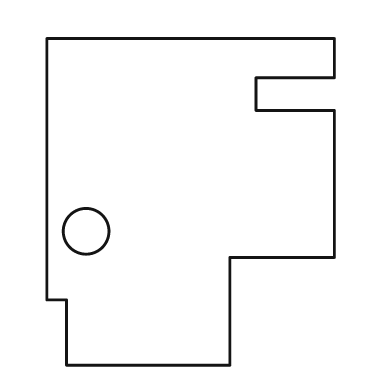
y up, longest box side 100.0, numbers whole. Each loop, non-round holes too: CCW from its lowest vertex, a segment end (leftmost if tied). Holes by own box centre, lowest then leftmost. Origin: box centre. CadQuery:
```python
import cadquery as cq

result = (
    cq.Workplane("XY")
    .moveTo(-38.0, -50.0)
    .lineTo(12.0, -50.0)
    .lineTo(12.0, -17.0)
    .lineTo(44.0, -17.0)
    .lineTo(44.0, 28.0)
    .lineTo(20.0, 28.0)
    .lineTo(20.0, 38.0)
    .lineTo(44.0, 38.0)
    .lineTo(44.0, 50.0)
    .lineTo(-44.0, 50.0)
    .lineTo(-44.0, -30.0)
    .lineTo(-38.0, -30.0)
    .close()
    .moveTo(-32.0, -9.0)
    .circle(7.0)
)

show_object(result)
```